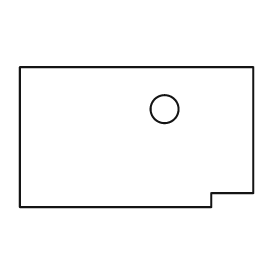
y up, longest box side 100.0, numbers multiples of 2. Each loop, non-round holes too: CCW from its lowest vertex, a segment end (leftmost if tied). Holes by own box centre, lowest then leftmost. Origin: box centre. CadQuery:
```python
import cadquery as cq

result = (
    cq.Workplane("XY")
    .moveTo(-50.0, -30.0)
    .lineTo(32.0, -30.0)
    .lineTo(32.0, -24.0)
    .lineTo(50.0, -24.0)
    .lineTo(50.0, 30.0)
    .lineTo(-50.0, 30.0)
    .close()
    .moveTo(12.0, 12.0)
    .circle(6.0)
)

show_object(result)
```